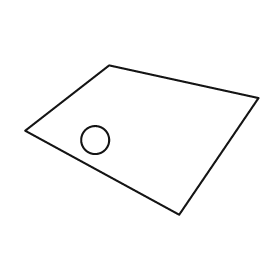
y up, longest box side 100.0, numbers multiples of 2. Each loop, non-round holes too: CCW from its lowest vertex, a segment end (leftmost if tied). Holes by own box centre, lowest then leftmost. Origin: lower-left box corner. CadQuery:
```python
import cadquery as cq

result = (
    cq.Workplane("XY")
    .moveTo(66.0, 0.0)
    .lineTo(100.0, 50.0)
    .lineTo(36.0, 64.0)
    .lineTo(0.0, 36.0)
    .close()
    .moveTo(30.0, 32.0)
    .circle(6.0)
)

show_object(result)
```